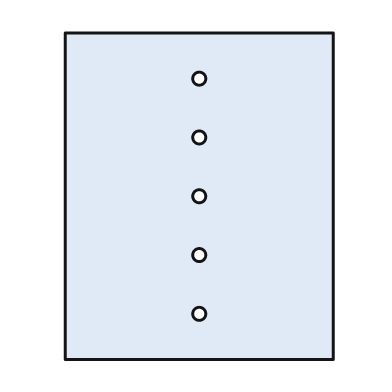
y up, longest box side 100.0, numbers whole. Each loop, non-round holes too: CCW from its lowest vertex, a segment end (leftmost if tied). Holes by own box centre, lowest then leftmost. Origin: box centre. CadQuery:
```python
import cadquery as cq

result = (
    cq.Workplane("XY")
    .moveTo(-41.0, -50.0)
    .lineTo(41.0, -50.0)
    .lineTo(41.0, 50.0)
    .lineTo(-41.0, 50.0)
    .close()
    .moveTo(0.0, -36.0)
    .circle(2.0)
    .moveTo(0.0, -18.0)
    .circle(2.0)
    .moveTo(0.0, 0.0)
    .circle(2.0)
    .moveTo(0.0, 18.0)
    .circle(2.0)
    .moveTo(0.0, 36.0)
    .circle(2.0)
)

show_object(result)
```